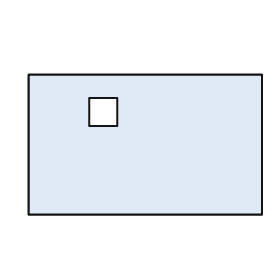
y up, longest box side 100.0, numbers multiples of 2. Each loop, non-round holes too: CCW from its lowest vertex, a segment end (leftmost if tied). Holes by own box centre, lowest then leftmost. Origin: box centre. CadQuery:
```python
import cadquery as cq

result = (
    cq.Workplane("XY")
    .moveTo(-50.0, -30.0)
    .lineTo(50.0, -30.0)
    .lineTo(50.0, 30.0)
    .lineTo(-50.0, 30.0)
    .close()
    .moveTo(-24.0, 8.0)
    .lineTo(-12.0, 8.0)
    .lineTo(-12.0, 20.0)
    .lineTo(-24.0, 20.0)
    .close()
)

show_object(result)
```